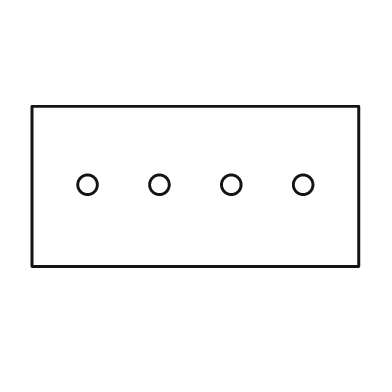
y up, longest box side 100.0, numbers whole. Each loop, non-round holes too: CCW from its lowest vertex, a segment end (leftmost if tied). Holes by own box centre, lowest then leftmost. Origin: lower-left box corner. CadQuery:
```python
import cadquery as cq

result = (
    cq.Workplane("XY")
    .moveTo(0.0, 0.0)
    .lineTo(100.0, 0.0)
    .lineTo(100.0, 49.0)
    .lineTo(0.0, 49.0)
    .close()
    .moveTo(17.0, 25.0)
    .circle(3.0)
    .moveTo(39.0, 25.0)
    .circle(3.0)
    .moveTo(61.0, 25.0)
    .circle(3.0)
    .moveTo(83.0, 25.0)
    .circle(3.0)
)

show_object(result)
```